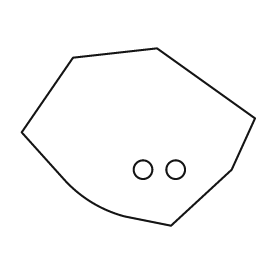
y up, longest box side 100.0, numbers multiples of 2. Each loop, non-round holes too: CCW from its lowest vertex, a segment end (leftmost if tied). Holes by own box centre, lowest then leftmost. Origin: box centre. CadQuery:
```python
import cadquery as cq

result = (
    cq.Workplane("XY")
    .moveTo(14.0, -38.0)
    .lineTo(40.0, -14.0)
    .lineTo(50.0, 8.0)
    .lineTo(8.0, 38.0)
    .lineTo(-28.0, 34.0)
    .lineTo(-50.0, 2.0)
    .lineTo(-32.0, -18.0)
    .threePointArc((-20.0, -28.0), (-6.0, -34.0))
    .close()
    .moveTo(2.0, -14.0)
    .circle(4.0)
    .moveTo(16.0, -14.0)
    .circle(4.0)
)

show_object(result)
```